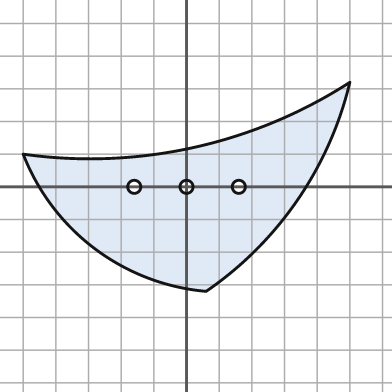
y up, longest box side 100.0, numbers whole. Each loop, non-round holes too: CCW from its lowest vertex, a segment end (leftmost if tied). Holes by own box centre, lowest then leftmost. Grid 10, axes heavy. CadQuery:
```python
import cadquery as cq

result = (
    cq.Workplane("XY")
    .moveTo(6.0, -32.0)
    .threePointArc((34.0, -4.0), (50.0, 32.0))
    .threePointArc((2.0, 12.0), (-50.0, 10.0))
    .threePointArc((-28.0, -19.0), (6.0, -32.0))
    .close()
    .moveTo(-16.0, 0.0)
    .circle(2.0)
    .moveTo(0.0, 0.0)
    .circle(2.0)
    .moveTo(16.0, 0.0)
    .circle(2.0)
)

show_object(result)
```